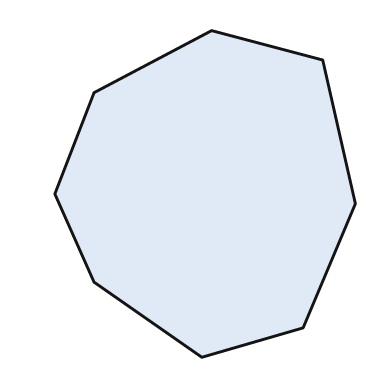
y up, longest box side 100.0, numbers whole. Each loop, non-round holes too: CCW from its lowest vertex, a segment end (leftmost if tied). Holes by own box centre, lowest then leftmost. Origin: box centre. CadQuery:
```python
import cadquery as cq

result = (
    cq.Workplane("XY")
    .moveTo(-1.0, -50.0)
    .lineTo(30.0, -41.0)
    .lineTo(46.0, -3.0)
    .lineTo(36.0, 41.0)
    .lineTo(2.0, 50.0)
    .lineTo(-34.0, 31.0)
    .lineTo(-46.0, 0.0)
    .lineTo(-34.0, -27.0)
    .close()
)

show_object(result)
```